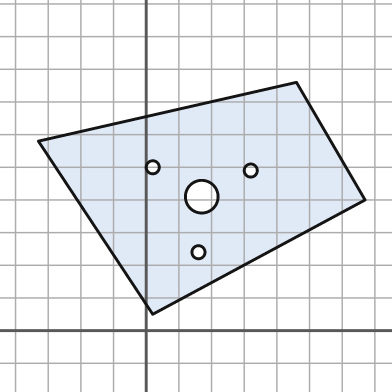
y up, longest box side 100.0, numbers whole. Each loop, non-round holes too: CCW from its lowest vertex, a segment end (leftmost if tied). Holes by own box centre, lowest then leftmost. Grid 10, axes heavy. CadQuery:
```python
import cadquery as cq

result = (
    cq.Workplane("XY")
    .moveTo(2.0, 5.0)
    .lineTo(67.0, 40.0)
    .lineTo(46.0, 76.0)
    .lineTo(-33.0, 58.0)
    .close()
    .moveTo(16.0, 24.0)
    .circle(2.0)
    .moveTo(17.0, 41.0)
    .circle(5.0)
    .moveTo(32.0, 49.0)
    .circle(2.0)
    .moveTo(2.0, 50.0)
    .circle(2.0)
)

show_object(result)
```